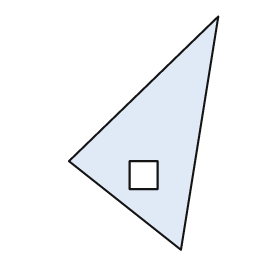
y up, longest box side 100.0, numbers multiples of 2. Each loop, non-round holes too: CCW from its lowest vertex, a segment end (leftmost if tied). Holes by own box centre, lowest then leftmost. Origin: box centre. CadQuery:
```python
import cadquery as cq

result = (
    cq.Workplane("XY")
    .moveTo(16.0, -50.0)
    .lineTo(32.0, 50.0)
    .lineTo(-32.0, -12.0)
    .close()
    .moveTo(-6.0, -24.0)
    .lineTo(6.0, -24.0)
    .lineTo(6.0, -12.0)
    .lineTo(-6.0, -12.0)
    .close()
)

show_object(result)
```